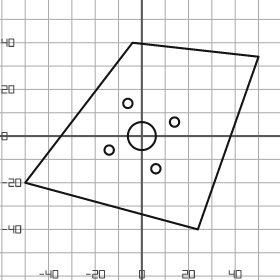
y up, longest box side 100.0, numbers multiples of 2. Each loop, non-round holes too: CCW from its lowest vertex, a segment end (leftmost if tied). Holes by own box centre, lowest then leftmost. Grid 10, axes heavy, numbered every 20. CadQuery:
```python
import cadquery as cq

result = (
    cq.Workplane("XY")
    .moveTo(24.0, -40.0)
    .lineTo(50.0, 34.0)
    .lineTo(-4.0, 40.0)
    .lineTo(-50.0, -20.0)
    .close()
    .moveTo(6.0, -14.0)
    .circle(2.0)
    .moveTo(-14.0, -6.0)
    .circle(2.0)
    .moveTo(0.0, 0.0)
    .circle(6.0)
    .moveTo(14.0, 6.0)
    .circle(2.0)
    .moveTo(-6.0, 14.0)
    .circle(2.0)
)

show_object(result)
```